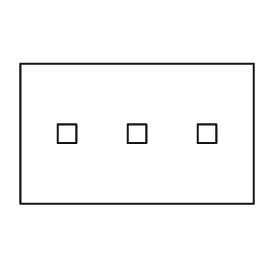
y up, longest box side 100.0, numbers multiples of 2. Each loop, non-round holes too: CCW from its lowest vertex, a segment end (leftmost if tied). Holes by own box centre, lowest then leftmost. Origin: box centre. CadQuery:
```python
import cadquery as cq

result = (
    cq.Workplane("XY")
    .moveTo(-50.0, -30.0)
    .lineTo(50.0, -30.0)
    .lineTo(50.0, 30.0)
    .lineTo(-50.0, 30.0)
    .close()
    .moveTo(-34.0, -4.0)
    .lineTo(-26.0, -4.0)
    .lineTo(-26.0, 4.0)
    .lineTo(-34.0, 4.0)
    .close()
    .moveTo(-4.0, -4.0)
    .lineTo(4.0, -4.0)
    .lineTo(4.0, 4.0)
    .lineTo(-4.0, 4.0)
    .close()
    .moveTo(26.0, -4.0)
    .lineTo(34.0, -4.0)
    .lineTo(34.0, 4.0)
    .lineTo(26.0, 4.0)
    .close()
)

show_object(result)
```